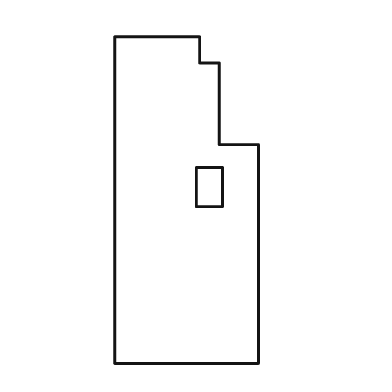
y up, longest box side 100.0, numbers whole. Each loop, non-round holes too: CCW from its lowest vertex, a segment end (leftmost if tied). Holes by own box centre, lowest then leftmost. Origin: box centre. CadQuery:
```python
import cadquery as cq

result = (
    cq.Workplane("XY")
    .moveTo(-22.0, -50.0)
    .lineTo(22.0, -50.0)
    .lineTo(22.0, 17.0)
    .lineTo(10.0, 17.0)
    .lineTo(10.0, 42.0)
    .lineTo(4.0, 42.0)
    .lineTo(4.0, 50.0)
    .lineTo(-22.0, 50.0)
    .close()
    .moveTo(3.0, -2.0)
    .lineTo(11.0, -2.0)
    .lineTo(11.0, 10.0)
    .lineTo(3.0, 10.0)
    .close()
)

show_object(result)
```